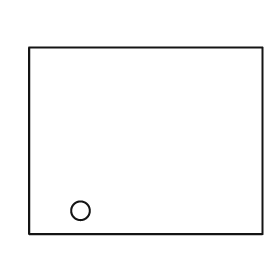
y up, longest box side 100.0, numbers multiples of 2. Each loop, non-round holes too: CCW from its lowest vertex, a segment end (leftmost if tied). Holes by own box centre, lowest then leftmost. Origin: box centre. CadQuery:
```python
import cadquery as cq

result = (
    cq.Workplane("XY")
    .moveTo(-50.0, -40.0)
    .lineTo(50.0, -40.0)
    .lineTo(50.0, 40.0)
    .lineTo(-50.0, 40.0)
    .close()
    .moveTo(-28.0, -30.0)
    .circle(4.0)
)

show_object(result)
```